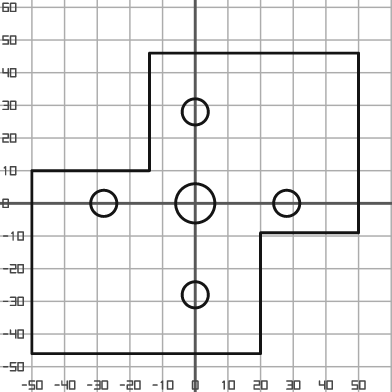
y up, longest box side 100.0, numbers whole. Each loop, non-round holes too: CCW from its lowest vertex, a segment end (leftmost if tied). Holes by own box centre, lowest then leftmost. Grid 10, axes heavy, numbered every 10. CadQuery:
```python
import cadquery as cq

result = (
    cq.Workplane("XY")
    .moveTo(-50.0, -46.0)
    .lineTo(20.0, -46.0)
    .lineTo(20.0, -9.0)
    .lineTo(50.0, -9.0)
    .lineTo(50.0, 46.0)
    .lineTo(-14.0, 46.0)
    .lineTo(-14.0, 10.0)
    .lineTo(-50.0, 10.0)
    .close()
    .moveTo(0.0, -28.0)
    .circle(4.0)
    .moveTo(-28.0, 0.0)
    .circle(4.0)
    .moveTo(0.0, 0.0)
    .circle(6.0)
    .moveTo(28.0, 0.0)
    .circle(4.0)
    .moveTo(0.0, 28.0)
    .circle(4.0)
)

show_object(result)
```